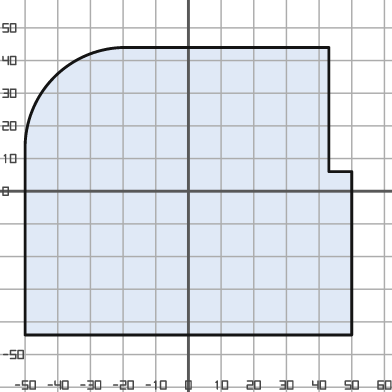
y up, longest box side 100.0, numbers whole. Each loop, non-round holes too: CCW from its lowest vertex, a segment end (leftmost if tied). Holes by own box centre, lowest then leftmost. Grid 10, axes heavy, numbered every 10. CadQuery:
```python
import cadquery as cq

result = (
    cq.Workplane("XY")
    .moveTo(-50.0, -44.0)
    .lineTo(50.0, -44.0)
    .lineTo(50.0, 6.0)
    .lineTo(43.0, 6.0)
    .lineTo(43.0, 44.0)
    .lineTo(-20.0, 44.0)
    .threePointArc((-41.0, 35.0), (-50.0, 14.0))
    .close()
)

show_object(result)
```